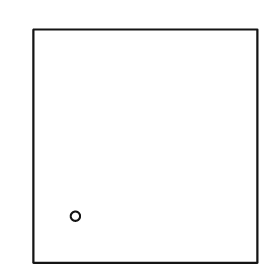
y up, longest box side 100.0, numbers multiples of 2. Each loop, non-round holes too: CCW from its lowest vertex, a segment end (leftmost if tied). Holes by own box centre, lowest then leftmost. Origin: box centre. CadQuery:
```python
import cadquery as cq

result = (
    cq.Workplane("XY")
    .moveTo(-48.0, -50.0)
    .lineTo(48.0, -50.0)
    .lineTo(48.0, 50.0)
    .lineTo(-48.0, 50.0)
    .close()
    .moveTo(-30.0, -30.0)
    .circle(2.0)
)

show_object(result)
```